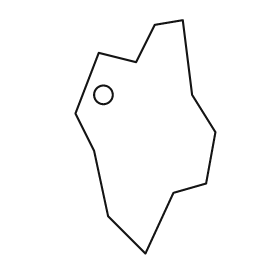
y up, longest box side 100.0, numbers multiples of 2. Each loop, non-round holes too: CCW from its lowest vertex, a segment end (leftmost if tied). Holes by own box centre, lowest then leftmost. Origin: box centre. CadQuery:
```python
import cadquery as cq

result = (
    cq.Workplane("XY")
    .moveTo(0.0, -50.0)
    .lineTo(12.0, -24.0)
    .lineTo(26.0, -20.0)
    .lineTo(30.0, 2.0)
    .lineTo(20.0, 18.0)
    .lineTo(16.0, 50.0)
    .lineTo(4.0, 48.0)
    .lineTo(-4.0, 32.0)
    .lineTo(-20.0, 36.0)
    .lineTo(-30.0, 10.0)
    .lineTo(-22.0, -6.0)
    .lineTo(-16.0, -34.0)
    .close()
    .moveTo(-18.0, 18.0)
    .circle(4.0)
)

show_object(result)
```